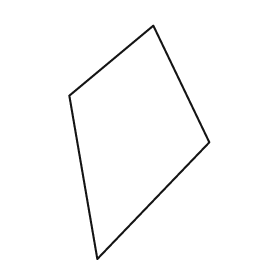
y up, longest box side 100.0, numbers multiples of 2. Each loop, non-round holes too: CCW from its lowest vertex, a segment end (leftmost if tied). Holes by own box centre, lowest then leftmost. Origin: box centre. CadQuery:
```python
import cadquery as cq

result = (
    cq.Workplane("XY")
    .moveTo(-18.0, -50.0)
    .lineTo(30.0, 0.0)
    .lineTo(6.0, 50.0)
    .lineTo(-30.0, 20.0)
    .close()
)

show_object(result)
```